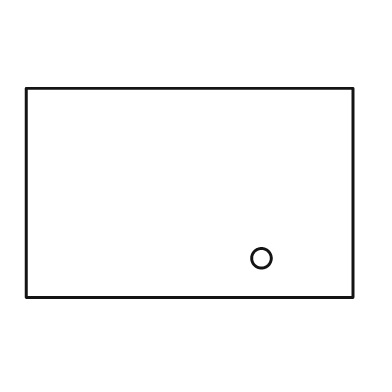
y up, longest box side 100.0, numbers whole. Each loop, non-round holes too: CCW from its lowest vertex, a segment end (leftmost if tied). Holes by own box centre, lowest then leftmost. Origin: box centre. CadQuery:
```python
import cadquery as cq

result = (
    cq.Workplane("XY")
    .moveTo(-50.0, -32.0)
    .lineTo(50.0, -32.0)
    .lineTo(50.0, 32.0)
    .lineTo(-50.0, 32.0)
    .close()
    .moveTo(22.0, -20.0)
    .circle(3.0)
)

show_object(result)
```